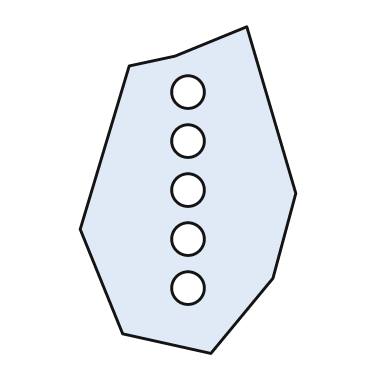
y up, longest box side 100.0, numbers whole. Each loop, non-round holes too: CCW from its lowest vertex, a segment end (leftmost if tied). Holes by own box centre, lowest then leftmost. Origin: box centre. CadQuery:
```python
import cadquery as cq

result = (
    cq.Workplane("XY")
    .moveTo(7.0, -50.0)
    .lineTo(26.0, -27.0)
    .lineTo(33.0, -1.0)
    .lineTo(18.0, 50.0)
    .lineTo(-4.0, 41.0)
    .lineTo(-18.0, 38.0)
    .lineTo(-33.0, -12.0)
    .lineTo(-20.0, -44.0)
    .close()
    .moveTo(0.0, -30.0)
    .circle(5.0)
    .moveTo(0.0, -15.0)
    .circle(5.0)
    .moveTo(0.0, 0.0)
    .circle(5.0)
    .moveTo(0.0, 15.0)
    .circle(5.0)
    .moveTo(0.0, 30.0)
    .circle(5.0)
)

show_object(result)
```